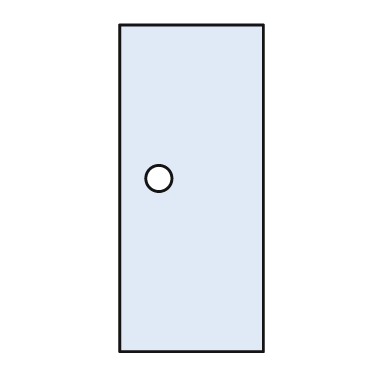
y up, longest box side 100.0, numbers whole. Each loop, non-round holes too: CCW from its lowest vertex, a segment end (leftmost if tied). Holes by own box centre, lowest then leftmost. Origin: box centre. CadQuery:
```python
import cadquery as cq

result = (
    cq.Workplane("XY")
    .moveTo(-22.0, -50.0)
    .lineTo(22.0, -50.0)
    .lineTo(22.0, 50.0)
    .lineTo(-22.0, 50.0)
    .close()
    .moveTo(-10.0, 3.0)
    .circle(4.0)
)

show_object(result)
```